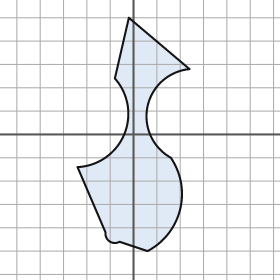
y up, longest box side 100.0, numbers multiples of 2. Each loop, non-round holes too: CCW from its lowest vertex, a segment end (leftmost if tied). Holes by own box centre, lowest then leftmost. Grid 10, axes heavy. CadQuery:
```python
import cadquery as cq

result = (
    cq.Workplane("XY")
    .moveTo(6.0, -50.0)
    .threePointArc((20.0, -32.0), (16.0, -10.0))
    .threePointArc((6.0, 12.0), (24.0, 28.0))
    .lineTo(-2.0, 50.0)
    .lineTo(-8.0, 24.0)
    .threePointArc((-4.0, 0.0), (-24.0, -14.0))
    .lineTo(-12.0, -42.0)
    .threePointArc((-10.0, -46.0), (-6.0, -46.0))
    .close()
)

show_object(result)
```